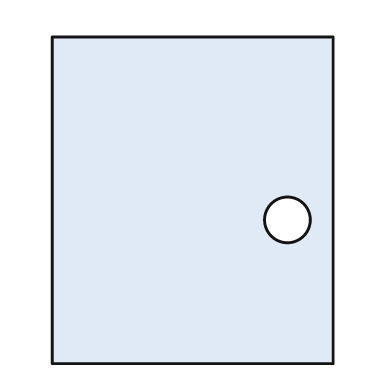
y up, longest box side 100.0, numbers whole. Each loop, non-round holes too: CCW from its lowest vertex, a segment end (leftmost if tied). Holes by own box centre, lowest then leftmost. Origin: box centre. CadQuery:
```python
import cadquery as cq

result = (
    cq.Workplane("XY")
    .moveTo(-43.0, -50.0)
    .lineTo(43.0, -50.0)
    .lineTo(43.0, 50.0)
    .lineTo(-43.0, 50.0)
    .close()
    .moveTo(29.0, -6.0)
    .circle(7.0)
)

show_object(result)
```